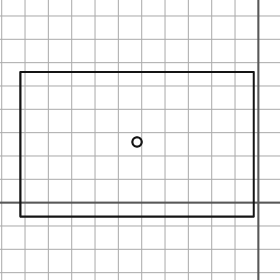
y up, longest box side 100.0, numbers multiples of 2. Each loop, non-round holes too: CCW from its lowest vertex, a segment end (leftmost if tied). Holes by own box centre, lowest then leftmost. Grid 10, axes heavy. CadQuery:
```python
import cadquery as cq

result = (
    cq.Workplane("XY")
    .moveTo(-102.0, -6.0)
    .lineTo(-2.0, -6.0)
    .lineTo(-2.0, 56.0)
    .lineTo(-102.0, 56.0)
    .close()
    .moveTo(-52.0, 26.0)
    .circle(2.0)
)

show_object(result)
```